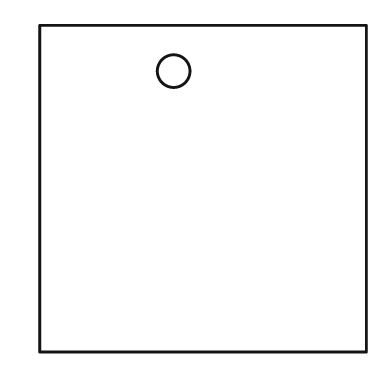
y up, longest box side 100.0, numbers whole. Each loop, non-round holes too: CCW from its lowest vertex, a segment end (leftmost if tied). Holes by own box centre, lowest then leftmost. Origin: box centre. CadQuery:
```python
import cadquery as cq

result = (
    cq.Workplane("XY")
    .moveTo(-50.0, -50.0)
    .lineTo(50.0, -50.0)
    .lineTo(50.0, 50.0)
    .lineTo(-50.0, 50.0)
    .close()
    .moveTo(-9.0, 36.0)
    .circle(5.0)
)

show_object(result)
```